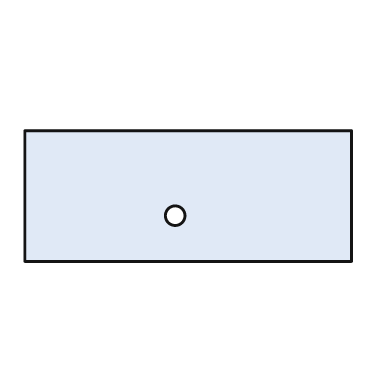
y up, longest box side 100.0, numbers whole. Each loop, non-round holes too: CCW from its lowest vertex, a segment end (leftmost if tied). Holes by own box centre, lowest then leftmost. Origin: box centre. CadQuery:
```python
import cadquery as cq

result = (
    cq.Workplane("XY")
    .moveTo(-50.0, -20.0)
    .lineTo(50.0, -20.0)
    .lineTo(50.0, 20.0)
    .lineTo(-50.0, 20.0)
    .close()
    .moveTo(-4.0, -6.0)
    .circle(3.0)
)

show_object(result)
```